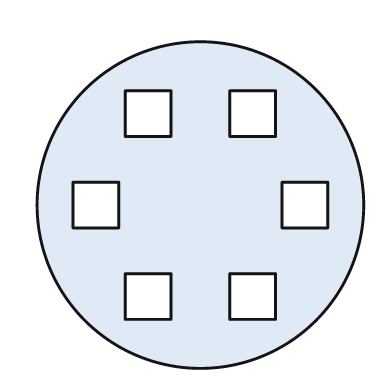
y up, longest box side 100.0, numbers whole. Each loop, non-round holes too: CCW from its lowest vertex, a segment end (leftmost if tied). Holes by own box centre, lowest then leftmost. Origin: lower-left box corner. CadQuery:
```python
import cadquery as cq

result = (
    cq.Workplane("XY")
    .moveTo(50.0, 50.0)
    .circle(50.0)
    .moveTo(27.0, 15.0)
    .lineTo(41.0, 15.0)
    .lineTo(41.0, 29.0)
    .lineTo(27.0, 29.0)
    .close()
    .moveTo(59.0, 15.0)
    .lineTo(73.0, 15.0)
    .lineTo(73.0, 29.0)
    .lineTo(59.0, 29.0)
    .close()
    .moveTo(11.0, 43.0)
    .lineTo(25.0, 43.0)
    .lineTo(25.0, 57.0)
    .lineTo(11.0, 57.0)
    .close()
    .moveTo(75.0, 43.0)
    .lineTo(89.0, 43.0)
    .lineTo(89.0, 57.0)
    .lineTo(75.0, 57.0)
    .close()
    .moveTo(27.0, 71.0)
    .lineTo(41.0, 71.0)
    .lineTo(41.0, 85.0)
    .lineTo(27.0, 85.0)
    .close()
    .moveTo(59.0, 71.0)
    .lineTo(73.0, 71.0)
    .lineTo(73.0, 85.0)
    .lineTo(59.0, 85.0)
    .close()
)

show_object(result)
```